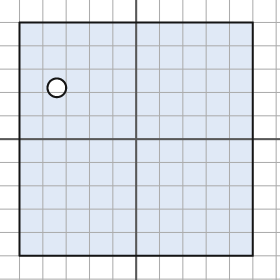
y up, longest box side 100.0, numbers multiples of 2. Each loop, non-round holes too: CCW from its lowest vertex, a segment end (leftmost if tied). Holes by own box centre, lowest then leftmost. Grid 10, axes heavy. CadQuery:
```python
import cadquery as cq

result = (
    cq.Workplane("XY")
    .moveTo(-50.0, -50.0)
    .lineTo(50.0, -50.0)
    .lineTo(50.0, 50.0)
    .lineTo(-50.0, 50.0)
    .close()
    .moveTo(-34.0, 22.0)
    .circle(4.0)
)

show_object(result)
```